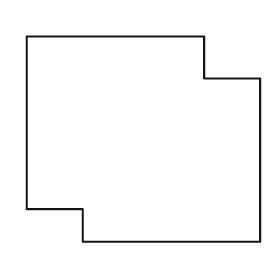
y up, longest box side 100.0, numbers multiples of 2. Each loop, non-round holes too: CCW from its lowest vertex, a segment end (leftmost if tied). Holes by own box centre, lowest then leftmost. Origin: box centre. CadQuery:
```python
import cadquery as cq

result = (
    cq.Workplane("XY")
    .moveTo(-26.0, -44.0)
    .lineTo(50.0, -44.0)
    .lineTo(50.0, 26.0)
    .lineTo(26.0, 26.0)
    .lineTo(26.0, 44.0)
    .lineTo(-50.0, 44.0)
    .lineTo(-50.0, -30.0)
    .lineTo(-26.0, -30.0)
    .close()
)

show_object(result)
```